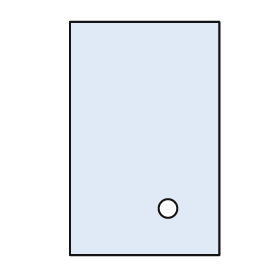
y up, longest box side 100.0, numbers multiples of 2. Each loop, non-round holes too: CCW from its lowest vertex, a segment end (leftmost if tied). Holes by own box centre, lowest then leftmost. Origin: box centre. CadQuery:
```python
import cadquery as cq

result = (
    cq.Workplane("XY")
    .moveTo(-32.0, -50.0)
    .lineTo(32.0, -50.0)
    .lineTo(32.0, 50.0)
    .lineTo(-32.0, 50.0)
    .close()
    .moveTo(10.0, -30.0)
    .circle(4.0)
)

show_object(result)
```